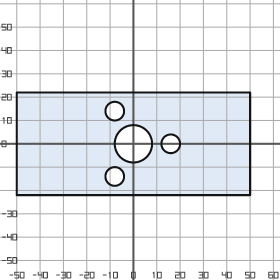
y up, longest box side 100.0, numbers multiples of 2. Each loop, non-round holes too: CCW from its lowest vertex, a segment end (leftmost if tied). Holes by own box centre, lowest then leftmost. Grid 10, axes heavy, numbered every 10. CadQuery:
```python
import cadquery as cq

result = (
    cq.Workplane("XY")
    .moveTo(-50.0, -22.0)
    .lineTo(50.0, -22.0)
    .lineTo(50.0, 22.0)
    .lineTo(-50.0, 22.0)
    .close()
    .moveTo(-8.0, -14.0)
    .circle(4.0)
    .moveTo(0.0, 0.0)
    .circle(8.0)
    .moveTo(16.0, 0.0)
    .circle(4.0)
    .moveTo(-8.0, 14.0)
    .circle(4.0)
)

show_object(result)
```